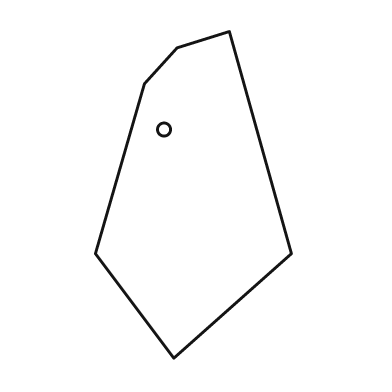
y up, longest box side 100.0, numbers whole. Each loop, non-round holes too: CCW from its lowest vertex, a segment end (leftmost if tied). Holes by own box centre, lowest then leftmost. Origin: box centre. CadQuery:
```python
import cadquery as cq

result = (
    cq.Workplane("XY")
    .moveTo(-6.0, -50.0)
    .lineTo(30.0, -18.0)
    .lineTo(11.0, 50.0)
    .lineTo(-5.0, 45.0)
    .lineTo(-15.0, 34.0)
    .lineTo(-30.0, -18.0)
    .close()
    .moveTo(-9.0, 20.0)
    .circle(2.0)
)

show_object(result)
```